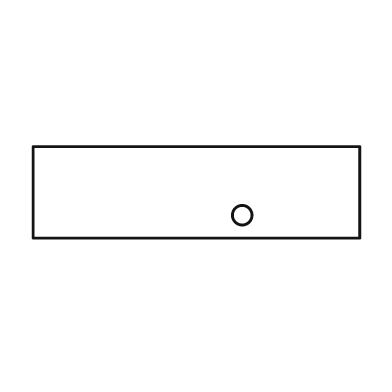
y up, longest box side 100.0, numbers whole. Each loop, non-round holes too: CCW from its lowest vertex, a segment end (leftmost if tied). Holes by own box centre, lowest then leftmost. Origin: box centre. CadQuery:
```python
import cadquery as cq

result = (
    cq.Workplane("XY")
    .moveTo(-50.0, -14.0)
    .lineTo(50.0, -14.0)
    .lineTo(50.0, 14.0)
    .lineTo(-50.0, 14.0)
    .close()
    .moveTo(14.0, -7.0)
    .circle(3.0)
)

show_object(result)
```